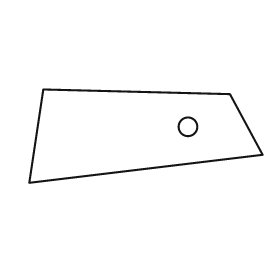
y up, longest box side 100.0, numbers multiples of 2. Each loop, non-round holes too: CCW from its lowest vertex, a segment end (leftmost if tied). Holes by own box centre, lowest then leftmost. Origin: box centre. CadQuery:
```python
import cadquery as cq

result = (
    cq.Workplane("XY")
    .moveTo(-50.0, -20.0)
    .lineTo(50.0, -8.0)
    .lineTo(36.0, 18.0)
    .lineTo(-44.0, 20.0)
    .close()
    .moveTo(18.0, 4.0)
    .circle(4.0)
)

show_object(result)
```